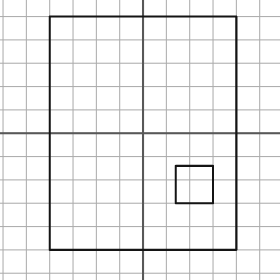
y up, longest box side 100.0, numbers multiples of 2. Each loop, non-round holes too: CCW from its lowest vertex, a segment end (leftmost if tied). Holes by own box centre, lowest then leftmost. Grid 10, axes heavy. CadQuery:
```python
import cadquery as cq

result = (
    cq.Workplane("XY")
    .moveTo(-40.0, -50.0)
    .lineTo(40.0, -50.0)
    .lineTo(40.0, 50.0)
    .lineTo(-40.0, 50.0)
    .close()
    .moveTo(14.0, -30.0)
    .lineTo(30.0, -30.0)
    .lineTo(30.0, -14.0)
    .lineTo(14.0, -14.0)
    .close()
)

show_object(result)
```